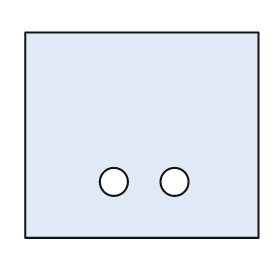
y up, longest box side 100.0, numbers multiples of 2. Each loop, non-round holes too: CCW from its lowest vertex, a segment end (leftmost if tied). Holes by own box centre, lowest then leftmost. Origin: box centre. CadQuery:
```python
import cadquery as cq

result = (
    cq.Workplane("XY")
    .moveTo(-50.0, -44.0)
    .lineTo(50.0, -44.0)
    .lineTo(50.0, 44.0)
    .lineTo(-50.0, 44.0)
    .close()
    .moveTo(-12.0, -20.0)
    .circle(6.0)
    .moveTo(14.0, -20.0)
    .circle(6.0)
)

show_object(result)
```